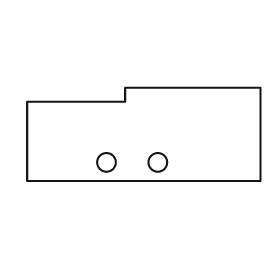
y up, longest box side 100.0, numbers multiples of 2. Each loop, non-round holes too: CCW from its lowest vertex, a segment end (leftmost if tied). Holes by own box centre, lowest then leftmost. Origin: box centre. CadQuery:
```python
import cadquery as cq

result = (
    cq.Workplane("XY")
    .moveTo(-50.0, -20.0)
    .lineTo(50.0, -20.0)
    .lineTo(50.0, 20.0)
    .lineTo(-8.0, 20.0)
    .lineTo(-8.0, 14.0)
    .lineTo(-50.0, 14.0)
    .close()
    .moveTo(-16.0, -12.0)
    .circle(4.0)
    .moveTo(6.0, -12.0)
    .circle(4.0)
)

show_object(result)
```